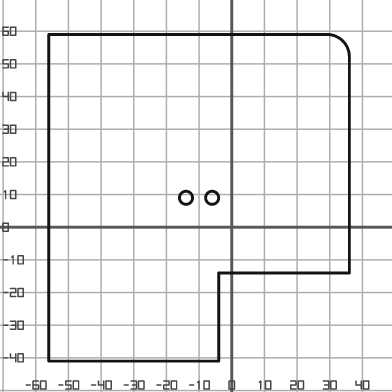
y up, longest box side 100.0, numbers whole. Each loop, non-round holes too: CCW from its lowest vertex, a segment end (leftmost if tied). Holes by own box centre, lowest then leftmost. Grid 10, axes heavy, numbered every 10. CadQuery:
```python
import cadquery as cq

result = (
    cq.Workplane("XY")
    .moveTo(-56.0, -41.0)
    .lineTo(-4.0, -41.0)
    .lineTo(-4.0, -14.0)
    .lineTo(36.0, -14.0)
    .lineTo(36.0, 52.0)
    .threePointArc((34.0, 57.0), (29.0, 59.0))
    .lineTo(-56.0, 59.0)
    .close()
    .moveTo(-14.0, 9.0)
    .circle(2.0)
    .moveTo(-6.0, 9.0)
    .circle(2.0)
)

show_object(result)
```